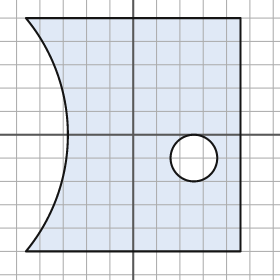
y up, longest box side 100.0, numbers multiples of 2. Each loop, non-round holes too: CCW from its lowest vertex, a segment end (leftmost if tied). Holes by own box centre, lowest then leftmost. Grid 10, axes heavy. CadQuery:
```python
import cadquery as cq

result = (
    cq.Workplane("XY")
    .moveTo(-46.0, -50.0)
    .lineTo(46.0, -50.0)
    .lineTo(46.0, 50.0)
    .lineTo(-46.0, 50.0)
    .threePointArc((-28.0, 0.0), (-46.0, -50.0))
    .close()
    .moveTo(26.0, -10.0)
    .circle(10.0)
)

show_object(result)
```